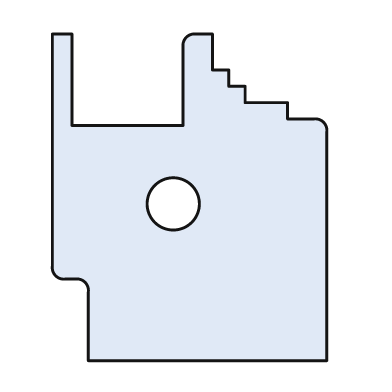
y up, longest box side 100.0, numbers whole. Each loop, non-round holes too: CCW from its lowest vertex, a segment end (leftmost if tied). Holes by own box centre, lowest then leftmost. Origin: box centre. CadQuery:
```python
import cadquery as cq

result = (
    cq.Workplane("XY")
    .moveTo(-31.0, -50.0)
    .lineTo(42.0, -50.0)
    .lineTo(42.0, 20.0)
    .threePointArc((41.0, 23.0), (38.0, 24.0))
    .lineTo(30.0, 24.0)
    .lineTo(30.0, 29.0)
    .lineTo(17.0, 29.0)
    .lineTo(17.0, 34.0)
    .lineTo(12.0, 34.0)
    .lineTo(12.0, 39.0)
    .lineTo(7.0, 39.0)
    .lineTo(7.0, 50.0)
    .lineTo(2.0, 50.0)
    .threePointArc((-1.0, 49.0), (-2.0, 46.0))
    .lineTo(-2.0, 22.0)
    .lineTo(-36.0, 22.0)
    .lineTo(-36.0, 50.0)
    .lineTo(-42.0, 50.0)
    .lineTo(-42.0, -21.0)
    .threePointArc((-41.0, -24.0), (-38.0, -25.0))
    .lineTo(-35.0, -25.0)
    .threePointArc((-32.0, -26.0), (-31.0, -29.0))
    .close()
    .moveTo(-5.0, -2.0)
    .circle(8.0)
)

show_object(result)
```